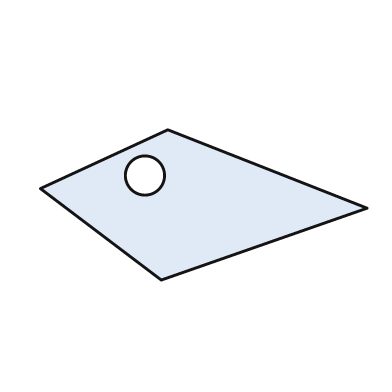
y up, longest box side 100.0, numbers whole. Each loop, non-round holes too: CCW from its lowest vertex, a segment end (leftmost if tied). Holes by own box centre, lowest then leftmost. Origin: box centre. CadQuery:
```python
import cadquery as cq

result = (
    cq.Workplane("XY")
    .moveTo(-13.0, -23.0)
    .lineTo(50.0, -1.0)
    .lineTo(-11.0, 23.0)
    .lineTo(-50.0, 5.0)
    .close()
    .moveTo(-18.0, 9.0)
    .circle(6.0)
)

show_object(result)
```